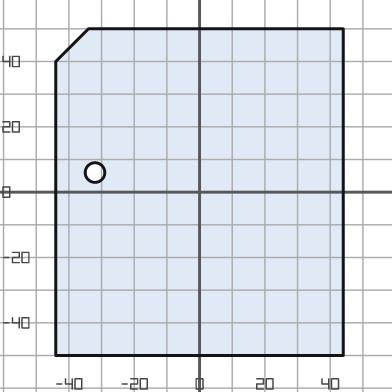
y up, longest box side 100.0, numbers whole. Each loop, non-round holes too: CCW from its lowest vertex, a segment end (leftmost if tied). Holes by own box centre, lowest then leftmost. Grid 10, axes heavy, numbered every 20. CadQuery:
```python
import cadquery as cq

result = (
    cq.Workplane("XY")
    .moveTo(-44.0, -50.0)
    .lineTo(44.0, -50.0)
    .lineTo(44.0, 50.0)
    .lineTo(-34.0, 50.0)
    .lineTo(-44.0, 40.0)
    .close()
    .moveTo(-32.0, 6.0)
    .circle(3.0)
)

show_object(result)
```